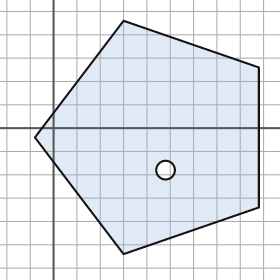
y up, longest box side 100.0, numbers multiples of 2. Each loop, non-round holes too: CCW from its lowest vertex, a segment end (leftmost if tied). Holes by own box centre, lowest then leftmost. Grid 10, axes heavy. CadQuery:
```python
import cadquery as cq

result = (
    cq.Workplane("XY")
    .moveTo(30.0, -54.0)
    .lineTo(88.0, -34.0)
    .lineTo(88.0, 26.0)
    .lineTo(30.0, 46.0)
    .lineTo(-8.0, -4.0)
    .close()
    .moveTo(48.0, -18.0)
    .circle(4.0)
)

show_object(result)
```